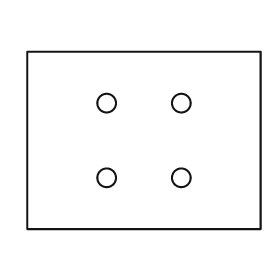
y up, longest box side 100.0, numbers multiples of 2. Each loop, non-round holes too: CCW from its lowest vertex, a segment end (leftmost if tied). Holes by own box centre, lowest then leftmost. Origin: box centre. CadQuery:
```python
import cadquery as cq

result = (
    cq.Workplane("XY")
    .moveTo(-50.0, -38.0)
    .lineTo(50.0, -38.0)
    .lineTo(50.0, 38.0)
    .lineTo(-50.0, 38.0)
    .close()
    .moveTo(-16.0, -16.0)
    .circle(4.0)
    .moveTo(16.0, -16.0)
    .circle(4.0)
    .moveTo(-16.0, 16.0)
    .circle(4.0)
    .moveTo(16.0, 16.0)
    .circle(4.0)
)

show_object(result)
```